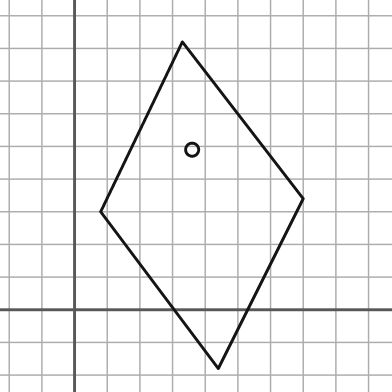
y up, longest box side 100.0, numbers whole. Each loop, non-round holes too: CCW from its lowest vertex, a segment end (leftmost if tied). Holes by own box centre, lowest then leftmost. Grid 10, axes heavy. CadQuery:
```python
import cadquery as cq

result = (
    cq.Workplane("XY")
    .moveTo(44.0, -18.0)
    .lineTo(70.0, 34.0)
    .lineTo(33.0, 82.0)
    .lineTo(8.0, 30.0)
    .close()
    .moveTo(36.0, 49.0)
    .circle(2.0)
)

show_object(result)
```